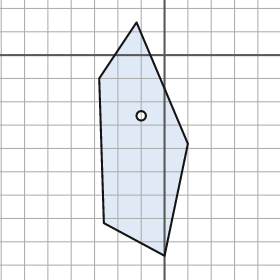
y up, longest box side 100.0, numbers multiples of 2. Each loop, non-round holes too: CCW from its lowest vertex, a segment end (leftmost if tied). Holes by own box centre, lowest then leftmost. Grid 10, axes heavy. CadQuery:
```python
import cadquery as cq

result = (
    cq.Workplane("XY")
    .moveTo(0.0, -86.0)
    .lineTo(10.0, -38.0)
    .lineTo(-12.0, 14.0)
    .lineTo(-28.0, -10.0)
    .lineTo(-26.0, -72.0)
    .close()
    .moveTo(-10.0, -26.0)
    .circle(2.0)
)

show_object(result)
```